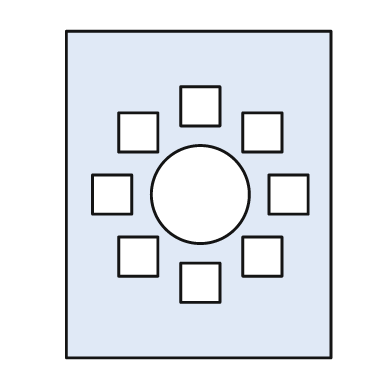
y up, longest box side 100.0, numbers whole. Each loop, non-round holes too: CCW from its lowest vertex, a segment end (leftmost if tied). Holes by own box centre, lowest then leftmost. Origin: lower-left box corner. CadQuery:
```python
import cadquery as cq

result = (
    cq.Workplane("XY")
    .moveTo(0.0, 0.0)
    .lineTo(81.0, 0.0)
    .lineTo(81.0, 100.0)
    .lineTo(0.0, 100.0)
    .close()
    .moveTo(35.0, 17.0)
    .lineTo(47.0, 17.0)
    .lineTo(47.0, 29.0)
    .lineTo(35.0, 29.0)
    .close()
    .moveTo(16.0, 25.0)
    .lineTo(28.0, 25.0)
    .lineTo(28.0, 37.0)
    .lineTo(16.0, 37.0)
    .close()
    .moveTo(54.0, 25.0)
    .lineTo(66.0, 25.0)
    .lineTo(66.0, 37.0)
    .lineTo(54.0, 37.0)
    .close()
    .moveTo(8.0, 44.0)
    .lineTo(20.0, 44.0)
    .lineTo(20.0, 56.0)
    .lineTo(8.0, 56.0)
    .close()
    .moveTo(41.0, 50.0)
    .circle(15.0)
    .moveTo(62.0, 44.0)
    .lineTo(74.0, 44.0)
    .lineTo(74.0, 56.0)
    .lineTo(62.0, 56.0)
    .close()
    .moveTo(16.0, 63.0)
    .lineTo(28.0, 63.0)
    .lineTo(28.0, 75.0)
    .lineTo(16.0, 75.0)
    .close()
    .moveTo(54.0, 63.0)
    .lineTo(66.0, 63.0)
    .lineTo(66.0, 75.0)
    .lineTo(54.0, 75.0)
    .close()
    .moveTo(35.0, 71.0)
    .lineTo(47.0, 71.0)
    .lineTo(47.0, 83.0)
    .lineTo(35.0, 83.0)
    .close()
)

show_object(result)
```